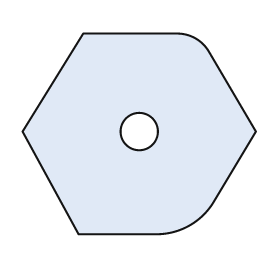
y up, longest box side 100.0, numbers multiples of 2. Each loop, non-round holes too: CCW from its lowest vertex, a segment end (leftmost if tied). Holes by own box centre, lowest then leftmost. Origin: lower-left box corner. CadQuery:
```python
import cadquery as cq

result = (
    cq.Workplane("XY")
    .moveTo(24.0, 0.0)
    .lineTo(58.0, 0.0)
    .threePointArc((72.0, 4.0), (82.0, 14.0))
    .lineTo(100.0, 44.0)
    .lineTo(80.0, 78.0)
    .threePointArc((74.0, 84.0), (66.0, 86.0))
    .lineTo(26.0, 86.0)
    .lineTo(0.0, 44.0)
    .close()
    .moveTo(50.0, 44.0)
    .circle(8.0)
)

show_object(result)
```